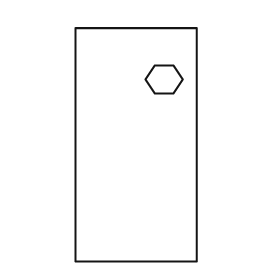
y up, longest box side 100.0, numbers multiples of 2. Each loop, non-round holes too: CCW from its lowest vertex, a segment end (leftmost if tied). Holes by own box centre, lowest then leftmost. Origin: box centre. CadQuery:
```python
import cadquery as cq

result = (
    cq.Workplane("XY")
    .moveTo(-26.0, -50.0)
    .lineTo(26.0, -50.0)
    .lineTo(26.0, 50.0)
    .lineTo(-26.0, 50.0)
    .close()
    .moveTo(8.0, 22.0)
    .lineTo(16.0, 22.0)
    .lineTo(20.0, 28.0)
    .lineTo(16.0, 34.0)
    .lineTo(8.0, 34.0)
    .lineTo(4.0, 28.0)
    .close()
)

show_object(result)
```